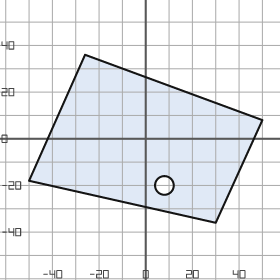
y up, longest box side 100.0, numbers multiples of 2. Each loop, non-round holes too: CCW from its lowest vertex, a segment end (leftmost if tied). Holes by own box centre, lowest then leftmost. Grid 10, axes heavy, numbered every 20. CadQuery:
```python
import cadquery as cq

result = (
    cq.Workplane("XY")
    .moveTo(30.0, -36.0)
    .lineTo(50.0, 8.0)
    .lineTo(-26.0, 36.0)
    .lineTo(-50.0, -18.0)
    .close()
    .moveTo(8.0, -20.0)
    .circle(4.0)
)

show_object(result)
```